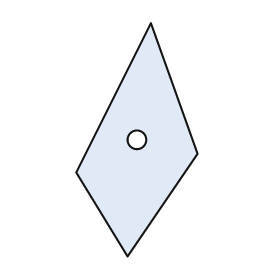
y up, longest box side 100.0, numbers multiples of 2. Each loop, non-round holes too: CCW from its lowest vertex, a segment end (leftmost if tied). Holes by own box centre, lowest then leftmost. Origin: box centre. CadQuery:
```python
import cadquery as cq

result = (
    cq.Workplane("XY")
    .moveTo(-4.0, -50.0)
    .lineTo(26.0, -6.0)
    .lineTo(6.0, 50.0)
    .lineTo(-26.0, -14.0)
    .close()
    .moveTo(0.0, 0.0)
    .circle(4.0)
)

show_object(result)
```